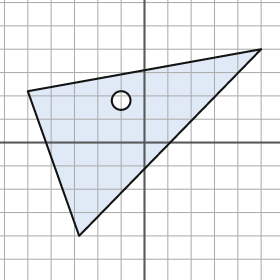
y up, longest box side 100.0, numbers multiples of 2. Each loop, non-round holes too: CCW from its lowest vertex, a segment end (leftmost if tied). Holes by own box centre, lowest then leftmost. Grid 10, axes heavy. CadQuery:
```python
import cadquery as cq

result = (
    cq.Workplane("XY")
    .moveTo(-28.0, -40.0)
    .lineTo(50.0, 40.0)
    .lineTo(-50.0, 22.0)
    .close()
    .moveTo(-10.0, 18.0)
    .circle(4.0)
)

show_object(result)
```